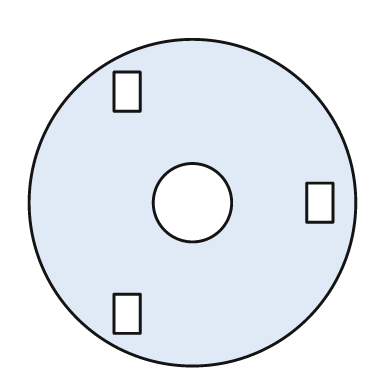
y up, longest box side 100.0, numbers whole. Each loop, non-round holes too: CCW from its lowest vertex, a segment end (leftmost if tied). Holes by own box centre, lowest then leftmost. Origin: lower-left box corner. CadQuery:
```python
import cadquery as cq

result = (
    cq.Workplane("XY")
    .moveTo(50.0, 50.0)
    .circle(50.0)
    .moveTo(26.0, 10.0)
    .lineTo(34.0, 10.0)
    .lineTo(34.0, 22.0)
    .lineTo(26.0, 22.0)
    .close()
    .moveTo(50.0, 50.0)
    .circle(12.0)
    .moveTo(85.0, 44.0)
    .lineTo(93.0, 44.0)
    .lineTo(93.0, 56.0)
    .lineTo(85.0, 56.0)
    .close()
    .moveTo(26.0, 78.0)
    .lineTo(34.0, 78.0)
    .lineTo(34.0, 90.0)
    .lineTo(26.0, 90.0)
    .close()
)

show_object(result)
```